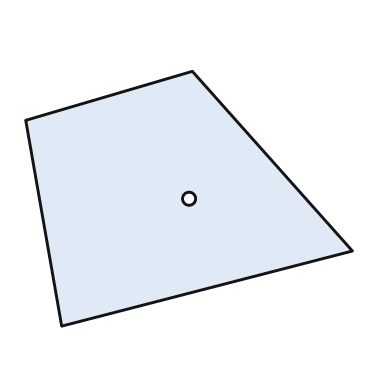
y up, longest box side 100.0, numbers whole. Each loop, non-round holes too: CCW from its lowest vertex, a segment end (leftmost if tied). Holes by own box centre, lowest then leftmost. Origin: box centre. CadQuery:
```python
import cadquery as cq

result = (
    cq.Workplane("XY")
    .moveTo(-39.0, -39.0)
    .lineTo(50.0, -16.0)
    .lineTo(1.0, 39.0)
    .lineTo(-50.0, 24.0)
    .close()
    .moveTo(0.0, 0.0)
    .circle(2.0)
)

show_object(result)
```